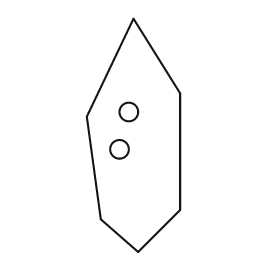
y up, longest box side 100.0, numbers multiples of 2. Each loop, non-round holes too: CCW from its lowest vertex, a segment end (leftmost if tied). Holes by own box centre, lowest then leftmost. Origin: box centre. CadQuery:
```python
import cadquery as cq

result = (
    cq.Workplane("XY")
    .moveTo(2.0, -50.0)
    .lineTo(20.0, -32.0)
    .lineTo(20.0, 18.0)
    .lineTo(0.0, 50.0)
    .lineTo(-20.0, 8.0)
    .lineTo(-14.0, -36.0)
    .close()
    .moveTo(-6.0, -6.0)
    .circle(4.0)
    .moveTo(-2.0, 10.0)
    .circle(4.0)
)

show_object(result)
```